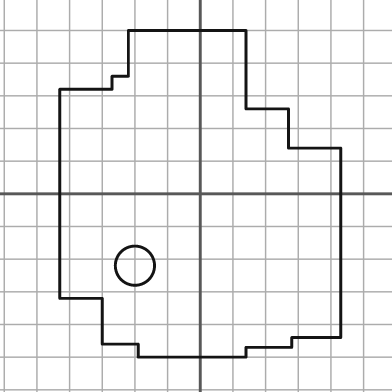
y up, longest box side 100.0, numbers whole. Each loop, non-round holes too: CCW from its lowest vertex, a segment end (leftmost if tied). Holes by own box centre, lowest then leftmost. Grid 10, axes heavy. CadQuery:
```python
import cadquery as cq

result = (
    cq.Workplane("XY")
    .moveTo(-19.0, -50.0)
    .lineTo(14.0, -50.0)
    .lineTo(14.0, -47.0)
    .lineTo(28.0, -47.0)
    .lineTo(28.0, -44.0)
    .lineTo(43.0, -44.0)
    .lineTo(43.0, 14.0)
    .lineTo(27.0, 14.0)
    .lineTo(27.0, 26.0)
    .lineTo(14.0, 26.0)
    .lineTo(14.0, 50.0)
    .lineTo(-22.0, 50.0)
    .lineTo(-22.0, 36.0)
    .lineTo(-27.0, 36.0)
    .lineTo(-27.0, 32.0)
    .lineTo(-43.0, 32.0)
    .lineTo(-43.0, -32.0)
    .lineTo(-30.0, -32.0)
    .lineTo(-30.0, -46.0)
    .lineTo(-19.0, -46.0)
    .close()
    .moveTo(-20.0, -22.0)
    .circle(6.0)
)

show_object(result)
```